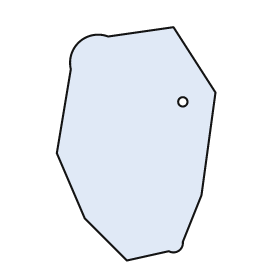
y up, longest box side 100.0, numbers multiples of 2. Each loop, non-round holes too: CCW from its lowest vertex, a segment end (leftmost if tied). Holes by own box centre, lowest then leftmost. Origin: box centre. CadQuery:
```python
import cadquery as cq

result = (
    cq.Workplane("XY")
    .moveTo(-4.0, -50.0)
    .lineTo(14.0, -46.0)
    .threePointArc((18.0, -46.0), (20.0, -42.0))
    .lineTo(28.0, -22.0)
    .lineTo(34.0, 22.0)
    .lineTo(16.0, 50.0)
    .lineTo(-12.0, 46.0)
    .threePointArc((-24.0, 44.0), (-28.0, 32.0))
    .lineTo(-34.0, -4.0)
    .lineTo(-22.0, -32.0)
    .close()
    .moveTo(20.0, 18.0)
    .circle(2.0)
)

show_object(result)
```